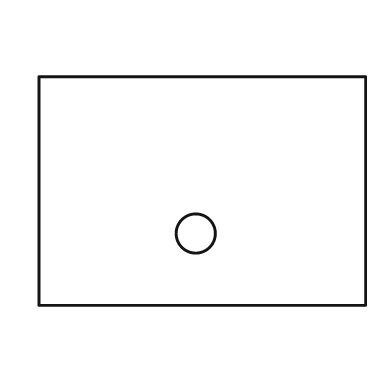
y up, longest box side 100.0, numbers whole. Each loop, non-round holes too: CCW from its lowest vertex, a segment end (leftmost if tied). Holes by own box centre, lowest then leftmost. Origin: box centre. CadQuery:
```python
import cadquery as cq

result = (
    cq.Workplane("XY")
    .moveTo(-50.0, -35.0)
    .lineTo(50.0, -35.0)
    .lineTo(50.0, 35.0)
    .lineTo(-50.0, 35.0)
    .close()
    .moveTo(-2.0, -13.0)
    .circle(6.0)
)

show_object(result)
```